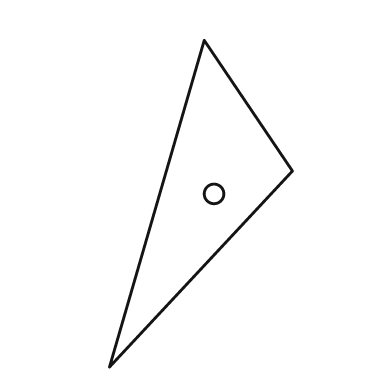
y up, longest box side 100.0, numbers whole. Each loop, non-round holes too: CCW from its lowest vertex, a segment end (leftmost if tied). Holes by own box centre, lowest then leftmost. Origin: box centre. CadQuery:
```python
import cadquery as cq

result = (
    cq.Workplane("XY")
    .moveTo(-28.0, -50.0)
    .lineTo(28.0, 10.0)
    .lineTo(1.0, 50.0)
    .close()
    .moveTo(4.0, 3.0)
    .circle(3.0)
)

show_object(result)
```